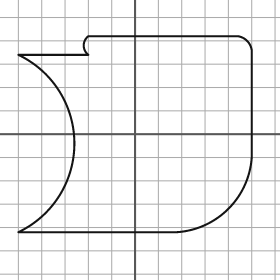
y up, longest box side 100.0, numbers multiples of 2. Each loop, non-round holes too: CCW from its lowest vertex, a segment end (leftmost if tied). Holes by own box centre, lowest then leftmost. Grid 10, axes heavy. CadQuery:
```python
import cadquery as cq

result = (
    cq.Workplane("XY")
    .moveTo(-50.0, -42.0)
    .lineTo(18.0, -42.0)
    .threePointArc((40.0, -32.0), (50.0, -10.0))
    .lineTo(50.0, 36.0)
    .threePointArc((48.0, 40.0), (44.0, 42.0))
    .lineTo(-20.0, 42.0)
    .threePointArc((-22.0, 38.0), (-20.0, 34.0))
    .lineTo(-50.0, 34.0)
    .threePointArc((-26.0, -4.0), (-50.0, -42.0))
    .close()
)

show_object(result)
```